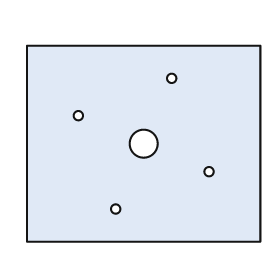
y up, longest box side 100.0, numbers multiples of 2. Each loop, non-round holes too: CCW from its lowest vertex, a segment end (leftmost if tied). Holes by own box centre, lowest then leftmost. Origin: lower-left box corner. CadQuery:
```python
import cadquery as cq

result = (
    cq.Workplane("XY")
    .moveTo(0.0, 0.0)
    .lineTo(100.0, 0.0)
    .lineTo(100.0, 84.0)
    .lineTo(0.0, 84.0)
    .close()
    .moveTo(38.0, 14.0)
    .circle(2.0)
    .moveTo(78.0, 30.0)
    .circle(2.0)
    .moveTo(50.0, 42.0)
    .circle(6.0)
    .moveTo(22.0, 54.0)
    .circle(2.0)
    .moveTo(62.0, 70.0)
    .circle(2.0)
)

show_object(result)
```